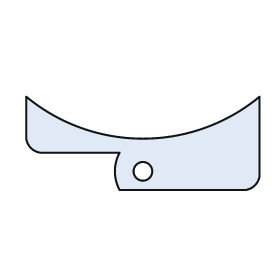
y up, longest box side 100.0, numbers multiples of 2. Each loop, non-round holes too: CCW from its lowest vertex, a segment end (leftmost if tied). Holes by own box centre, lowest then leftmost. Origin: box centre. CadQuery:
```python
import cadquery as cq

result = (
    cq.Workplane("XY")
    .moveTo(-10.0, -20.0)
    .lineTo(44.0, -20.0)
    .threePointArc((48.0, -18.0), (50.0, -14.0))
    .lineTo(50.0, 20.0)
    .threePointArc((0.0, 2.0), (-50.0, 20.0))
    .lineTo(-50.0, 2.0)
    .threePointArc((-48.0, -2.0), (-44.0, -4.0))
    .lineTo(-10.0, -4.0)
    .threePointArc((-12.0, -12.0), (-10.0, -20.0))
    .close()
    .moveTo(0.0, -12.0)
    .circle(4.0)
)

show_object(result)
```